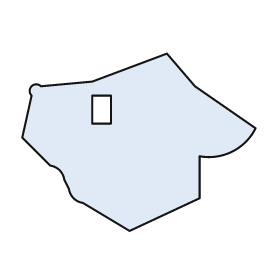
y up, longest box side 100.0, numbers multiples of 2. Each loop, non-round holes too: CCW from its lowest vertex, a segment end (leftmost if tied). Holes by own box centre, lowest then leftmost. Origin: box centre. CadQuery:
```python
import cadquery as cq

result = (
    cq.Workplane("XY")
    .moveTo(-4.0, -38.0)
    .lineTo(26.0, -24.0)
    .lineTo(26.0, -6.0)
    .threePointArc((40.0, -4.0), (50.0, 6.0))
    .lineTo(24.0, 24.0)
    .lineTo(12.0, 38.0)
    .lineTo(-20.0, 26.0)
    .lineTo(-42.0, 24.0)
    .threePointArc((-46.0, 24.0), (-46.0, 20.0))
    .lineTo(-50.0, 2.0)
    .lineTo(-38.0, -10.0)
    .threePointArc((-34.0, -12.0), (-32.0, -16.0))
    .lineTo(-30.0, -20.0)
    .threePointArc((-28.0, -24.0), (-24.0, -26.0))
    .close()
    .moveTo(-20.0, 8.0)
    .lineTo(-12.0, 8.0)
    .lineTo(-12.0, 20.0)
    .lineTo(-20.0, 20.0)
    .close()
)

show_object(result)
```